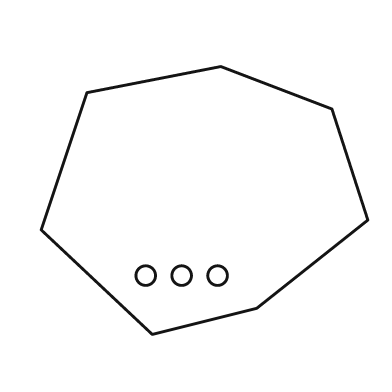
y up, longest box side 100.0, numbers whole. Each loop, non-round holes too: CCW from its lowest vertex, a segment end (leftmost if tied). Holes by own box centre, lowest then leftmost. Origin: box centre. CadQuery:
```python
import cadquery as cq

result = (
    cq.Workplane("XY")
    .moveTo(-16.0, -41.0)
    .lineTo(16.0, -33.0)
    .lineTo(50.0, -6.0)
    .lineTo(39.0, 28.0)
    .lineTo(5.0, 41.0)
    .lineTo(-36.0, 33.0)
    .lineTo(-50.0, -9.0)
    .close()
    .moveTo(-18.0, -23.0)
    .circle(3.0)
    .moveTo(-7.0, -23.0)
    .circle(3.0)
    .moveTo(4.0, -23.0)
    .circle(3.0)
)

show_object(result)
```